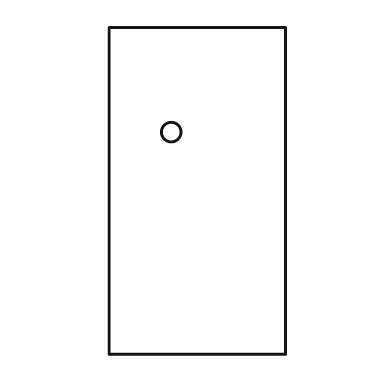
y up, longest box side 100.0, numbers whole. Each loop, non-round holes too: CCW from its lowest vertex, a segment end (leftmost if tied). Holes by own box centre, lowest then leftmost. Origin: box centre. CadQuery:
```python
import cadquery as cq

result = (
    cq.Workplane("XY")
    .moveTo(-27.0, -50.0)
    .lineTo(27.0, -50.0)
    .lineTo(27.0, 50.0)
    .lineTo(-27.0, 50.0)
    .close()
    .moveTo(-8.0, 18.0)
    .circle(3.0)
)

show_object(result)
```